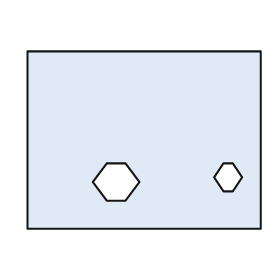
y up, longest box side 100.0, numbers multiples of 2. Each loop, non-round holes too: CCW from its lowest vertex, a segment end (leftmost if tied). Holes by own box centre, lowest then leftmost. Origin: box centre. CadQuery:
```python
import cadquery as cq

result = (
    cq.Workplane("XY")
    .moveTo(-50.0, -38.0)
    .lineTo(50.0, -38.0)
    .lineTo(50.0, 38.0)
    .lineTo(-50.0, 38.0)
    .close()
    .moveTo(-16.0, -26.0)
    .lineTo(-8.0, -26.0)
    .lineTo(-2.0, -18.0)
    .lineTo(-8.0, -10.0)
    .lineTo(-16.0, -10.0)
    .lineTo(-22.0, -18.0)
    .close()
    .moveTo(34.0, -22.0)
    .lineTo(38.0, -22.0)
    .lineTo(42.0, -16.0)
    .lineTo(38.0, -10.0)
    .lineTo(34.0, -10.0)
    .lineTo(30.0, -16.0)
    .close()
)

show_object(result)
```